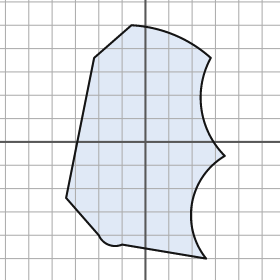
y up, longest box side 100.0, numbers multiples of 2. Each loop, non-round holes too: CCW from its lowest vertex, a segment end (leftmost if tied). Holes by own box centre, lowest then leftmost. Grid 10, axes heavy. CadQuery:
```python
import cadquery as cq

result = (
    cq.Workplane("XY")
    .moveTo(26.0, -50.0)
    .threePointArc((20.0, -26.0), (34.0, -6.0))
    .threePointArc((24.0, 14.0), (28.0, 36.0))
    .threePointArc((12.0, 46.0), (-6.0, 50.0))
    .lineTo(-22.0, 36.0)
    .lineTo(-34.0, -24.0)
    .lineTo(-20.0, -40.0)
    .threePointArc((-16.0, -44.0), (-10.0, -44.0))
    .close()
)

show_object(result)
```